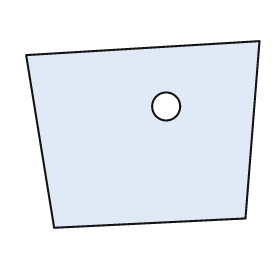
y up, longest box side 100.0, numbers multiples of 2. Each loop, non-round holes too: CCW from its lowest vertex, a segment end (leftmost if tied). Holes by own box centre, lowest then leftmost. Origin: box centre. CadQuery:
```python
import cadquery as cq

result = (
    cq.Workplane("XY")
    .moveTo(-38.0, -40.0)
    .lineTo(44.0, -36.0)
    .lineTo(50.0, 40.0)
    .lineTo(-50.0, 34.0)
    .close()
    .moveTo(10.0, 12.0)
    .circle(6.0)
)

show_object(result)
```